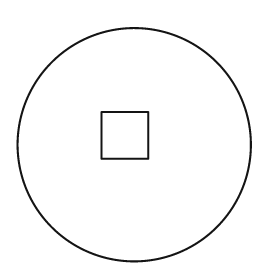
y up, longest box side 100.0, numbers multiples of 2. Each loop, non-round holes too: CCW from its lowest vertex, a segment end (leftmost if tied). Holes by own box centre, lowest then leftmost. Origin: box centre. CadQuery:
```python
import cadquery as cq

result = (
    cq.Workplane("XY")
    .moveTo(0.0, 0.0)
    .circle(50.0)
    .moveTo(-14.0, -6.0)
    .lineTo(6.0, -6.0)
    .lineTo(6.0, 14.0)
    .lineTo(-14.0, 14.0)
    .close()
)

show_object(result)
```